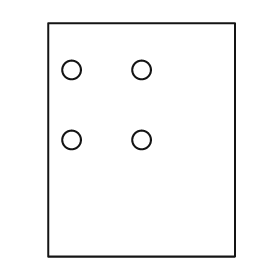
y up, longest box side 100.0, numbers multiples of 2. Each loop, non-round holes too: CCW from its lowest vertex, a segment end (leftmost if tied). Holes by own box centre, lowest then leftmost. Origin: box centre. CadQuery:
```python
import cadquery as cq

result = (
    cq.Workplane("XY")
    .moveTo(-40.0, -50.0)
    .lineTo(40.0, -50.0)
    .lineTo(40.0, 50.0)
    .lineTo(-40.0, 50.0)
    .close()
    .moveTo(-30.0, 0.0)
    .circle(4.0)
    .moveTo(0.0, 0.0)
    .circle(4.0)
    .moveTo(-30.0, 30.0)
    .circle(4.0)
    .moveTo(0.0, 30.0)
    .circle(4.0)
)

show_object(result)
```